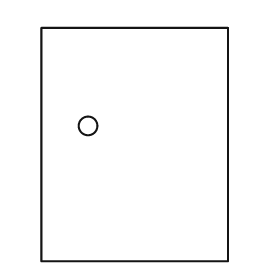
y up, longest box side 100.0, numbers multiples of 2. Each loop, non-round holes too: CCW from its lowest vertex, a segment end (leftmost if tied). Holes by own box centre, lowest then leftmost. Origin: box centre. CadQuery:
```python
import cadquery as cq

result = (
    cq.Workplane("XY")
    .moveTo(-40.0, -50.0)
    .lineTo(40.0, -50.0)
    .lineTo(40.0, 50.0)
    .lineTo(-40.0, 50.0)
    .close()
    .moveTo(-20.0, 8.0)
    .circle(4.0)
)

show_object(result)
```